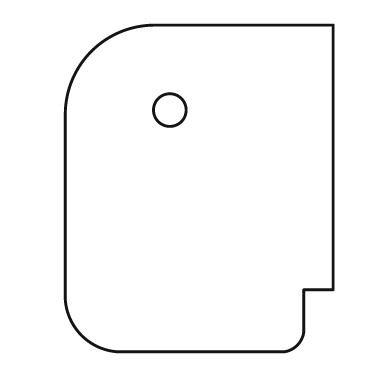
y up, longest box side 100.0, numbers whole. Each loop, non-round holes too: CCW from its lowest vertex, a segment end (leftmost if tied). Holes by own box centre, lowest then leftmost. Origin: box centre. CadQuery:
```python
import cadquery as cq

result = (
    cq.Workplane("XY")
    .moveTo(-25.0, -50.0)
    .lineTo(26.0, -50.0)
    .threePointArc((30.0, -48.0), (32.0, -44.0))
    .lineTo(32.0, -31.0)
    .lineTo(41.0, -31.0)
    .lineTo(41.0, 50.0)
    .lineTo(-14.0, 50.0)
    .threePointArc((-33.0, 42.0), (-41.0, 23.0))
    .lineTo(-41.0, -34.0)
    .threePointArc((-36.0, -45.0), (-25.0, -50.0))
    .close()
    .moveTo(-9.0, 24.0)
    .circle(5.0)
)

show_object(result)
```